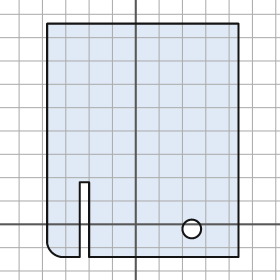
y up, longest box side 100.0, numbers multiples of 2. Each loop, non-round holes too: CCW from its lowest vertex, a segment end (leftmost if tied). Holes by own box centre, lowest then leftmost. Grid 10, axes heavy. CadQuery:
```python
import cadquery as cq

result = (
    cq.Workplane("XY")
    .moveTo(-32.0, -14.0)
    .lineTo(-24.0, -14.0)
    .lineTo(-24.0, 18.0)
    .lineTo(-20.0, 18.0)
    .lineTo(-20.0, -14.0)
    .lineTo(44.0, -14.0)
    .lineTo(44.0, 86.0)
    .lineTo(-38.0, 86.0)
    .lineTo(-38.0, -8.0)
    .threePointArc((-36.0, -12.0), (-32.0, -14.0))
    .close()
    .moveTo(24.0, -2.0)
    .circle(4.0)
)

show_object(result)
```